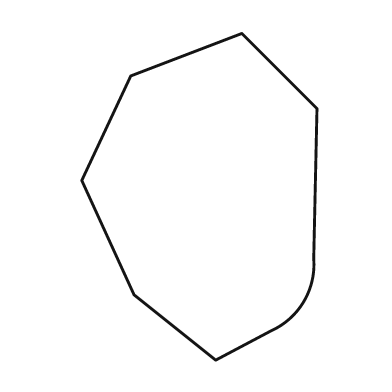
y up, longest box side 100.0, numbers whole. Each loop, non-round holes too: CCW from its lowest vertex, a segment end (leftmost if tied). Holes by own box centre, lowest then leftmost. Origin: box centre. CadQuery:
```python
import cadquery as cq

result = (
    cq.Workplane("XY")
    .moveTo(5.0, -50.0)
    .lineTo(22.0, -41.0)
    .threePointArc((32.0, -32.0), (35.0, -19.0))
    .lineTo(36.0, 27.0)
    .lineTo(13.0, 50.0)
    .lineTo(-21.0, 37.0)
    .lineTo(-36.0, 5.0)
    .lineTo(-20.0, -30.0)
    .close()
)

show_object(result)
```